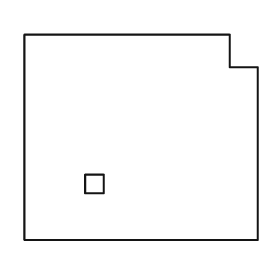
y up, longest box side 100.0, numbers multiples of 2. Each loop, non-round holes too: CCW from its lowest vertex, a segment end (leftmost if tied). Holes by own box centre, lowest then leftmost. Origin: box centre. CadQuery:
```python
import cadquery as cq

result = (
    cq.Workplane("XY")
    .moveTo(-50.0, -44.0)
    .lineTo(50.0, -44.0)
    .lineTo(50.0, 30.0)
    .lineTo(38.0, 30.0)
    .lineTo(38.0, 44.0)
    .lineTo(-50.0, 44.0)
    .close()
    .moveTo(-24.0, -24.0)
    .lineTo(-16.0, -24.0)
    .lineTo(-16.0, -16.0)
    .lineTo(-24.0, -16.0)
    .close()
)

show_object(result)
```